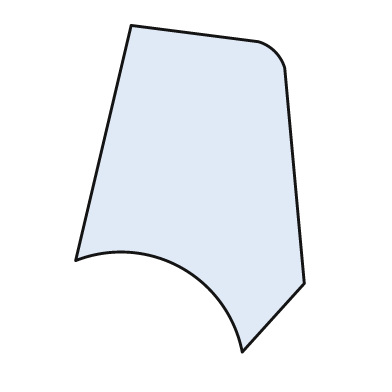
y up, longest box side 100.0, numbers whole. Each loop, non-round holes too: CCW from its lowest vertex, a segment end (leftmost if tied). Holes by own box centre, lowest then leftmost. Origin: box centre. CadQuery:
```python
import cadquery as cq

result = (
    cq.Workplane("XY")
    .moveTo(16.0, -50.0)
    .lineTo(35.0, -29.0)
    .lineTo(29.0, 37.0)
    .threePointArc((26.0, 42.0), (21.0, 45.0))
    .lineTo(-18.0, 50.0)
    .lineTo(-35.0, -22.0)
    .threePointArc((-3.0, -24.0), (16.0, -50.0))
    .close()
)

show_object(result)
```